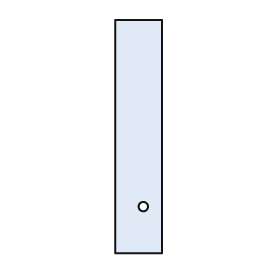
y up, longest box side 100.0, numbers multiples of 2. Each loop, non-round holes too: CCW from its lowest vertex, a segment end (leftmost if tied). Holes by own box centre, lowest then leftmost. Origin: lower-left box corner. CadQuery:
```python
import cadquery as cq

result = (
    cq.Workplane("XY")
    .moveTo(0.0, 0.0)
    .lineTo(20.0, 0.0)
    .lineTo(20.0, 100.0)
    .lineTo(0.0, 100.0)
    .close()
    .moveTo(12.0, 20.0)
    .circle(2.0)
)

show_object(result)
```